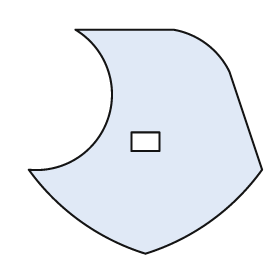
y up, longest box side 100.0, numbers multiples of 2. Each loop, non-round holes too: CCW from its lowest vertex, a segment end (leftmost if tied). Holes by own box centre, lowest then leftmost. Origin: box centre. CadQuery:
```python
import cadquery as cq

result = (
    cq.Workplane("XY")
    .moveTo(0.0, -48.0)
    .threePointArc((28.0, -34.0), (50.0, -12.0))
    .lineTo(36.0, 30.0)
    .threePointArc((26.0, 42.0), (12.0, 48.0))
    .lineTo(-30.0, 48.0)
    .threePointArc((-16.0, 10.0), (-50.0, -12.0))
    .threePointArc((-28.0, -34.0), (0.0, -48.0))
    .close()
    .moveTo(-6.0, -4.0)
    .lineTo(6.0, -4.0)
    .lineTo(6.0, 4.0)
    .lineTo(-6.0, 4.0)
    .close()
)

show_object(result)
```